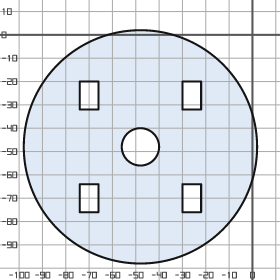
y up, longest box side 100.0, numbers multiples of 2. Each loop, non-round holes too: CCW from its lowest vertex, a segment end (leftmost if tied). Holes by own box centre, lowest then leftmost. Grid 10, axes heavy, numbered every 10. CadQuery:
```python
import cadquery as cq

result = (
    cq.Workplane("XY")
    .moveTo(-48.0, -48.0)
    .circle(50.0)
    .moveTo(-74.0, -76.0)
    .lineTo(-66.0, -76.0)
    .lineTo(-66.0, -64.0)
    .lineTo(-74.0, -64.0)
    .close()
    .moveTo(-30.0, -76.0)
    .lineTo(-22.0, -76.0)
    .lineTo(-22.0, -64.0)
    .lineTo(-30.0, -64.0)
    .close()
    .moveTo(-48.0, -48.0)
    .circle(8.0)
    .moveTo(-74.0, -32.0)
    .lineTo(-66.0, -32.0)
    .lineTo(-66.0, -20.0)
    .lineTo(-74.0, -20.0)
    .close()
    .moveTo(-30.0, -32.0)
    .lineTo(-22.0, -32.0)
    .lineTo(-22.0, -20.0)
    .lineTo(-30.0, -20.0)
    .close()
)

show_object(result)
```